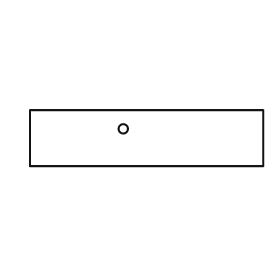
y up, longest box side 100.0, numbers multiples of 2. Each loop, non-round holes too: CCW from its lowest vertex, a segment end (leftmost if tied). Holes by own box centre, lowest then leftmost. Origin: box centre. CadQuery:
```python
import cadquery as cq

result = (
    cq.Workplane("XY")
    .moveTo(-50.0, -12.0)
    .lineTo(50.0, -12.0)
    .lineTo(50.0, 12.0)
    .lineTo(-50.0, 12.0)
    .close()
    .moveTo(-10.0, 4.0)
    .circle(2.0)
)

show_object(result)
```